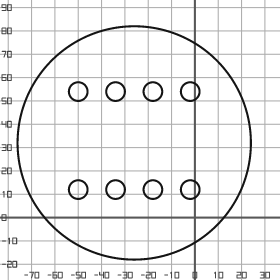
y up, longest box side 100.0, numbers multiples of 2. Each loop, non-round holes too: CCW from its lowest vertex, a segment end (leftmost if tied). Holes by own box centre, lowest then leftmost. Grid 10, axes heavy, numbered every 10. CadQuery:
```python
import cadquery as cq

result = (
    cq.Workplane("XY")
    .moveTo(-26.0, 32.0)
    .circle(50.0)
    .moveTo(-50.0, 12.0)
    .circle(4.0)
    .moveTo(-34.0, 12.0)
    .circle(4.0)
    .moveTo(-18.0, 12.0)
    .circle(4.0)
    .moveTo(-2.0, 12.0)
    .circle(4.0)
    .moveTo(-50.0, 54.0)
    .circle(4.0)
    .moveTo(-34.0, 54.0)
    .circle(4.0)
    .moveTo(-18.0, 54.0)
    .circle(4.0)
    .moveTo(-2.0, 54.0)
    .circle(4.0)
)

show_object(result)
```